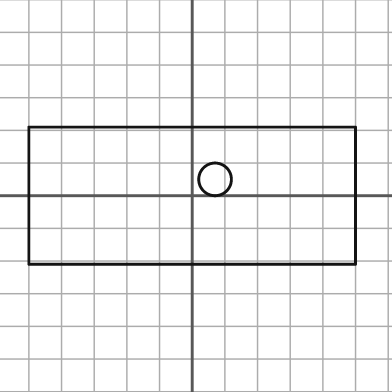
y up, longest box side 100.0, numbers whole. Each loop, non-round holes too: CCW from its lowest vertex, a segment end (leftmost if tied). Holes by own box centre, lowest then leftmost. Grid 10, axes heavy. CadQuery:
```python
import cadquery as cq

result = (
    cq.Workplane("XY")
    .moveTo(-50.0, -21.0)
    .lineTo(50.0, -21.0)
    .lineTo(50.0, 21.0)
    .lineTo(-50.0, 21.0)
    .close()
    .moveTo(7.0, 5.0)
    .circle(5.0)
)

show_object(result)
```